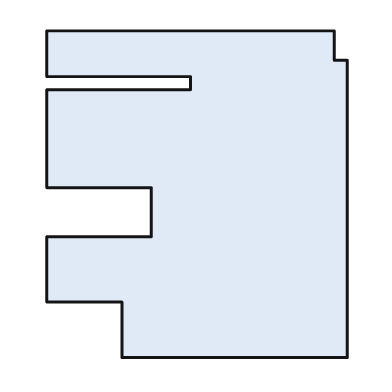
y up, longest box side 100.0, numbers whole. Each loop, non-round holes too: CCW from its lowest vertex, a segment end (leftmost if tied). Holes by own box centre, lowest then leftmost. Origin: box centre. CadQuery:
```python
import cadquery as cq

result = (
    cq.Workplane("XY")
    .moveTo(-23.0, -50.0)
    .lineTo(46.0, -50.0)
    .lineTo(46.0, 41.0)
    .lineTo(42.0, 41.0)
    .lineTo(42.0, 50.0)
    .lineTo(-46.0, 50.0)
    .lineTo(-46.0, 36.0)
    .lineTo(-2.0, 36.0)
    .lineTo(-2.0, 32.0)
    .lineTo(-46.0, 32.0)
    .lineTo(-46.0, 2.0)
    .lineTo(-14.0, 2.0)
    .lineTo(-14.0, -13.0)
    .lineTo(-46.0, -13.0)
    .lineTo(-46.0, -33.0)
    .lineTo(-23.0, -33.0)
    .close()
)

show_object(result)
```